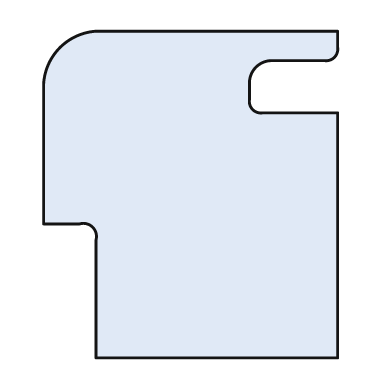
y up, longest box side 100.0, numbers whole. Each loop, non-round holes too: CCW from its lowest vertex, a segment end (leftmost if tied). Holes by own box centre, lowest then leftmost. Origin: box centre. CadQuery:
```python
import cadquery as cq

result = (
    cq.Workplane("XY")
    .moveTo(-29.0, -50.0)
    .lineTo(45.0, -50.0)
    .lineTo(45.0, 25.0)
    .lineTo(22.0, 25.0)
    .threePointArc((19.0, 26.0), (18.0, 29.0))
    .lineTo(18.0, 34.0)
    .threePointArc((20.0, 39.0), (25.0, 41.0))
    .lineTo(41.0, 41.0)
    .threePointArc((44.0, 42.0), (45.0, 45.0))
    .lineTo(45.0, 50.0)
    .lineTo(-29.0, 50.0)
    .threePointArc((-40.0, 45.0), (-45.0, 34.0))
    .lineTo(-45.0, -9.0)
    .lineTo(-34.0, -9.0)
    .threePointArc((-30.0, -10.0), (-29.0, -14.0))
    .close()
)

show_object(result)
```